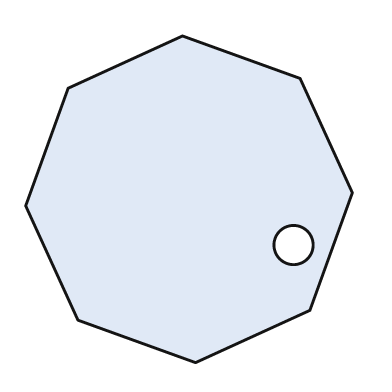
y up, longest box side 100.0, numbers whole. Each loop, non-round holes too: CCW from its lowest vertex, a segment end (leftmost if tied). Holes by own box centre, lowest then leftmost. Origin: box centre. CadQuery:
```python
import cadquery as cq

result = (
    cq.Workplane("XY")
    .moveTo(2.0, -50.0)
    .lineTo(37.0, -34.0)
    .lineTo(50.0, 2.0)
    .lineTo(34.0, 37.0)
    .lineTo(-2.0, 50.0)
    .lineTo(-37.0, 34.0)
    .lineTo(-50.0, -2.0)
    .lineTo(-34.0, -37.0)
    .close()
    .moveTo(32.0, -14.0)
    .circle(6.0)
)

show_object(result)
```